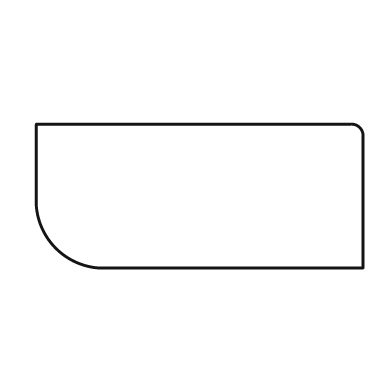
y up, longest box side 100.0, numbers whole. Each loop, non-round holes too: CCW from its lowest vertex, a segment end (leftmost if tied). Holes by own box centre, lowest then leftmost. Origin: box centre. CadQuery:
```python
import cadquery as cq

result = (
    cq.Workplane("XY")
    .moveTo(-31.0, -22.0)
    .lineTo(50.0, -22.0)
    .lineTo(50.0, 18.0)
    .threePointArc((49.0, 21.0), (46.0, 22.0))
    .lineTo(-50.0, 22.0)
    .lineTo(-50.0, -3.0)
    .threePointArc((-44.0, -16.0), (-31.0, -22.0))
    .close()
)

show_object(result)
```